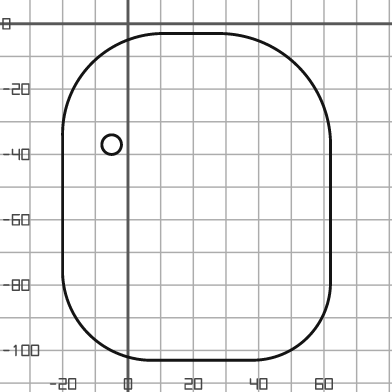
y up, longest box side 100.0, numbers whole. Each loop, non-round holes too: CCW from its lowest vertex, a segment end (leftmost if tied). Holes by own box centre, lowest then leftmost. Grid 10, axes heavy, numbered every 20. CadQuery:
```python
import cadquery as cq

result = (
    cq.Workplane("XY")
    .moveTo(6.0, -103.0)
    .lineTo(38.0, -103.0)
    .threePointArc((55.0, -96.0), (62.0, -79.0))
    .lineTo(62.0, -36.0)
    .threePointArc((52.0, -13.0), (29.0, -3.0))
    .lineTo(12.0, -3.0)
    .threePointArc((-11.0, -12.0), (-20.0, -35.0))
    .lineTo(-20.0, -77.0)
    .threePointArc((-12.0, -95.0), (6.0, -103.0))
    .close()
    .moveTo(-5.0, -37.0)
    .circle(3.0)
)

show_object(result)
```